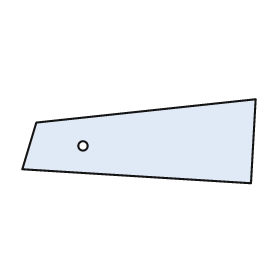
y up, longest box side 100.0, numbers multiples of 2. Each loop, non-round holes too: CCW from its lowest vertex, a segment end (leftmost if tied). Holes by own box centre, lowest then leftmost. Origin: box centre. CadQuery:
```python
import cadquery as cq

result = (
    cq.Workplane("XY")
    .moveTo(48.0, -18.0)
    .lineTo(50.0, 18.0)
    .lineTo(-44.0, 8.0)
    .lineTo(-50.0, -12.0)
    .close()
    .moveTo(-24.0, -2.0)
    .circle(2.0)
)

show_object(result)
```